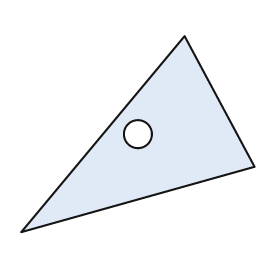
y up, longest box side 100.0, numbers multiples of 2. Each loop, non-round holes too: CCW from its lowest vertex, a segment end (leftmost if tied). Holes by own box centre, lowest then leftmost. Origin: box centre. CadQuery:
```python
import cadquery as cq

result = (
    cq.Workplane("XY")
    .moveTo(-50.0, -42.0)
    .lineTo(50.0, -14.0)
    .lineTo(20.0, 42.0)
    .close()
    .moveTo(0.0, 0.0)
    .circle(6.0)
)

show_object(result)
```